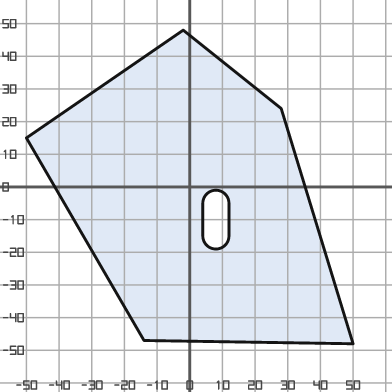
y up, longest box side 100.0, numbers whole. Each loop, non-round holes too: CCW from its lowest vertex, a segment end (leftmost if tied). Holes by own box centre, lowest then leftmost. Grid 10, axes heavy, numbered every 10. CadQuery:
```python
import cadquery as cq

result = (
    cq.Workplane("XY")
    .moveTo(50.0, -48.0)
    .lineTo(28.0, 24.0)
    .lineTo(-2.0, 48.0)
    .lineTo(-50.0, 15.0)
    .lineTo(-14.0, -47.0)
    .close()
    .moveTo(4.0, -15.0)
    .threePointArc((8.0, -19.0), (12.0, -15.0))
    .lineTo(12.0, -5.0)
    .threePointArc((8.0, -1.0), (4.0, -5.0))
    .close()
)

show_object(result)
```